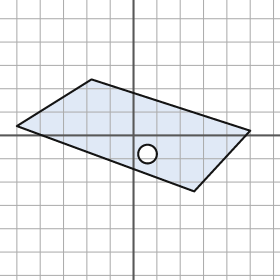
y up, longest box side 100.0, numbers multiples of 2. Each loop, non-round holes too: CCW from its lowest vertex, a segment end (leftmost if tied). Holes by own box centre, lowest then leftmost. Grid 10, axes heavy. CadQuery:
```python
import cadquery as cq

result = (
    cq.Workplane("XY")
    .moveTo(26.0, -24.0)
    .lineTo(50.0, 2.0)
    .lineTo(-18.0, 24.0)
    .lineTo(-50.0, 4.0)
    .close()
    .moveTo(6.0, -8.0)
    .circle(4.0)
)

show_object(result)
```